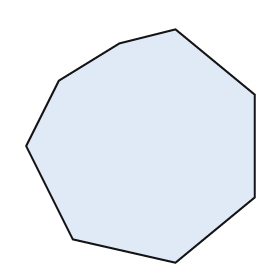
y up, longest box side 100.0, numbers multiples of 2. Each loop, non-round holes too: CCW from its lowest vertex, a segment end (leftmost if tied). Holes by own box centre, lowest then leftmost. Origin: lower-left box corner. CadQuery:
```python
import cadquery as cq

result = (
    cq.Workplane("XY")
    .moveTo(64.0, 0.0)
    .lineTo(98.0, 28.0)
    .lineTo(98.0, 72.0)
    .lineTo(64.0, 100.0)
    .lineTo(40.0, 94.0)
    .lineTo(14.0, 78.0)
    .lineTo(0.0, 50.0)
    .lineTo(20.0, 10.0)
    .close()
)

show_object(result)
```